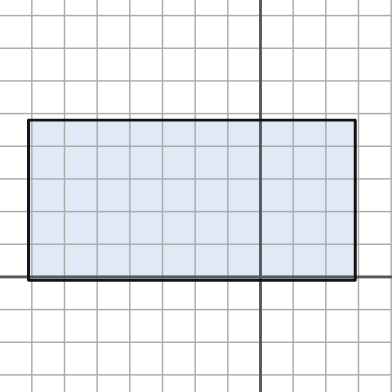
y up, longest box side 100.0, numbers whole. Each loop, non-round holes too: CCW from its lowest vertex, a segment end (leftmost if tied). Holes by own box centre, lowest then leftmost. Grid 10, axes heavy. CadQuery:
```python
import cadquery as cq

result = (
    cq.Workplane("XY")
    .moveTo(-71.0, -1.0)
    .lineTo(29.0, -1.0)
    .lineTo(29.0, 48.0)
    .lineTo(-71.0, 48.0)
    .close()
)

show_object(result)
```